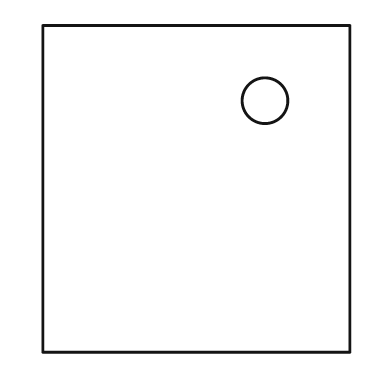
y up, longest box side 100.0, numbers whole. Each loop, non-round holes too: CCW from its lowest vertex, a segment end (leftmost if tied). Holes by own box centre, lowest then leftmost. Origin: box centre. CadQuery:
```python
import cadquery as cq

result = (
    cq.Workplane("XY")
    .moveTo(-47.0, -50.0)
    .lineTo(47.0, -50.0)
    .lineTo(47.0, 50.0)
    .lineTo(-47.0, 50.0)
    .close()
    .moveTo(21.0, 27.0)
    .circle(7.0)
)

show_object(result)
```